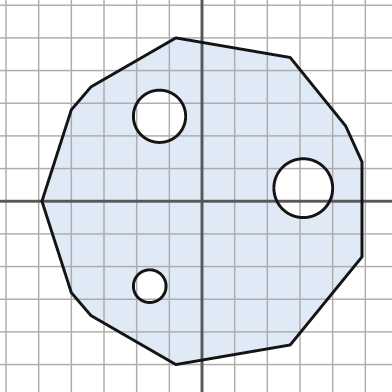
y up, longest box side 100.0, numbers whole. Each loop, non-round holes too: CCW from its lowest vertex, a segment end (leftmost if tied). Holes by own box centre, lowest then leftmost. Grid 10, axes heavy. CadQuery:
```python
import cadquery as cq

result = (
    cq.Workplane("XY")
    .moveTo(-8.0, -50.0)
    .lineTo(27.0, -44.0)
    .lineTo(49.0, -17.0)
    .lineTo(49.0, 12.0)
    .lineTo(44.0, 23.0)
    .lineTo(27.0, 44.0)
    .lineTo(-8.0, 50.0)
    .lineTo(-34.0, 35.0)
    .lineTo(-40.0, 28.0)
    .lineTo(-49.0, 0.0)
    .lineTo(-40.0, -28.0)
    .lineTo(-34.0, -35.0)
    .close()
    .moveTo(-16.0, -26.0)
    .circle(5.0)
    .moveTo(31.0, 4.0)
    .circle(9.0)
    .moveTo(-13.0, 26.0)
    .circle(8.0)
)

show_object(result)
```